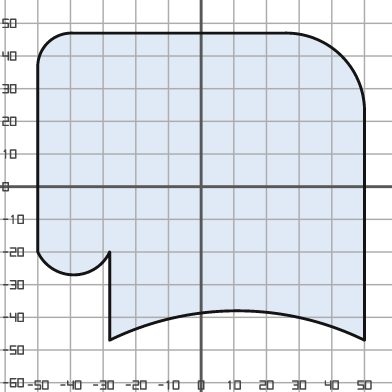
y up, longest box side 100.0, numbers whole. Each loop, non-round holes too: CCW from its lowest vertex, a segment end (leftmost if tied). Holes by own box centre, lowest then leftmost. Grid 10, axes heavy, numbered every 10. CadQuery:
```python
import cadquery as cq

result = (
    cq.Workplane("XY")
    .moveTo(-28.0, -47.0)
    .threePointArc((11.0, -38.0), (50.0, -47.0))
    .lineTo(50.0, 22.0)
    .threePointArc((43.0, 40.0), (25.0, 47.0))
    .lineTo(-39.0, 47.0)
    .threePointArc((-47.0, 44.0), (-50.0, 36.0))
    .lineTo(-50.0, -20.0)
    .threePointArc((-39.0, -27.0), (-28.0, -20.0))
    .close()
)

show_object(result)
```